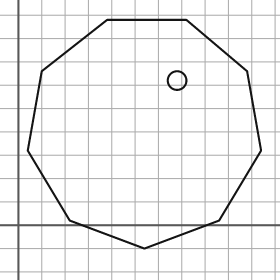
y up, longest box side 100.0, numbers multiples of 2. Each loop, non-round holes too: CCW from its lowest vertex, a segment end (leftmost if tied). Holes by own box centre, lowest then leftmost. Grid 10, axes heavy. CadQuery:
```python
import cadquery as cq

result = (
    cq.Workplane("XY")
    .moveTo(54.0, -10.0)
    .lineTo(86.0, 2.0)
    .lineTo(104.0, 32.0)
    .lineTo(98.0, 66.0)
    .lineTo(72.0, 88.0)
    .lineTo(38.0, 88.0)
    .lineTo(10.0, 66.0)
    .lineTo(4.0, 32.0)
    .lineTo(22.0, 2.0)
    .close()
    .moveTo(68.0, 62.0)
    .circle(4.0)
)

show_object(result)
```